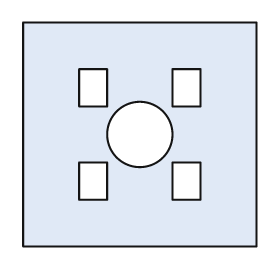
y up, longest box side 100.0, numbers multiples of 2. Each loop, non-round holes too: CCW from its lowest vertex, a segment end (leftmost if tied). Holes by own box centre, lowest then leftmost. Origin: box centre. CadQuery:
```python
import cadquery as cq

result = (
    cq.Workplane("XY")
    .moveTo(-50.0, -48.0)
    .lineTo(50.0, -48.0)
    .lineTo(50.0, 48.0)
    .lineTo(-50.0, 48.0)
    .close()
    .moveTo(-26.0, -28.0)
    .lineTo(-14.0, -28.0)
    .lineTo(-14.0, -12.0)
    .lineTo(-26.0, -12.0)
    .close()
    .moveTo(14.0, -28.0)
    .lineTo(26.0, -28.0)
    .lineTo(26.0, -12.0)
    .lineTo(14.0, -12.0)
    .close()
    .moveTo(0.0, 0.0)
    .circle(14.0)
    .moveTo(-26.0, 12.0)
    .lineTo(-14.0, 12.0)
    .lineTo(-14.0, 28.0)
    .lineTo(-26.0, 28.0)
    .close()
    .moveTo(14.0, 12.0)
    .lineTo(26.0, 12.0)
    .lineTo(26.0, 28.0)
    .lineTo(14.0, 28.0)
    .close()
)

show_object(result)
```